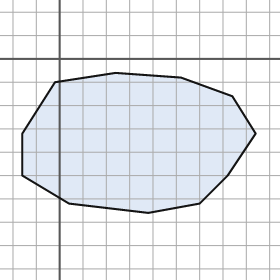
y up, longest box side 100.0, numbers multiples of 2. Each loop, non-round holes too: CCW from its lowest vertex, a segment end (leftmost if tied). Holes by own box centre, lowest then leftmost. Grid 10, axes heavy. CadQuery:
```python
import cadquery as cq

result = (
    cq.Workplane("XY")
    .moveTo(38.0, -66.0)
    .lineTo(60.0, -62.0)
    .lineTo(72.0, -50.0)
    .lineTo(84.0, -32.0)
    .lineTo(74.0, -16.0)
    .lineTo(52.0, -8.0)
    .lineTo(24.0, -6.0)
    .lineTo(-2.0, -10.0)
    .lineTo(-16.0, -32.0)
    .lineTo(-16.0, -50.0)
    .lineTo(4.0, -62.0)
    .close()
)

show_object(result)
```